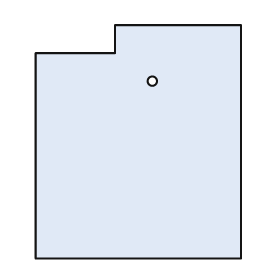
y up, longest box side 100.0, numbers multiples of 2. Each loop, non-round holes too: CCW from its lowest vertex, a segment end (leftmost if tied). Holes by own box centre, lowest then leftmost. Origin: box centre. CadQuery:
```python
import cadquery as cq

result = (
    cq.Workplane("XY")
    .moveTo(-44.0, -50.0)
    .lineTo(44.0, -50.0)
    .lineTo(44.0, 50.0)
    .lineTo(-10.0, 50.0)
    .lineTo(-10.0, 38.0)
    .lineTo(-44.0, 38.0)
    .close()
    .moveTo(6.0, 26.0)
    .circle(2.0)
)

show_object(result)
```